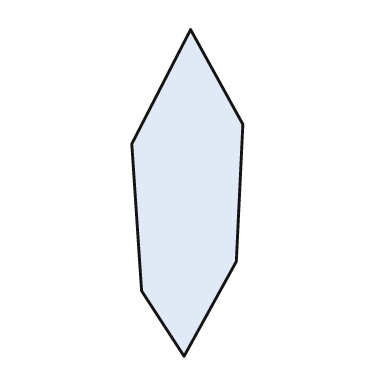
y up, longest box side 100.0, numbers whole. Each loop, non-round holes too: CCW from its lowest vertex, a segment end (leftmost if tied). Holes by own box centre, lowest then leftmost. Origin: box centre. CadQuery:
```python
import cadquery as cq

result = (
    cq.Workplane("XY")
    .moveTo(-1.0, -50.0)
    .lineTo(15.0, -21.0)
    .lineTo(17.0, 21.0)
    .lineTo(1.0, 50.0)
    .lineTo(-17.0, 15.0)
    .lineTo(-14.0, -30.0)
    .close()
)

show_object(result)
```